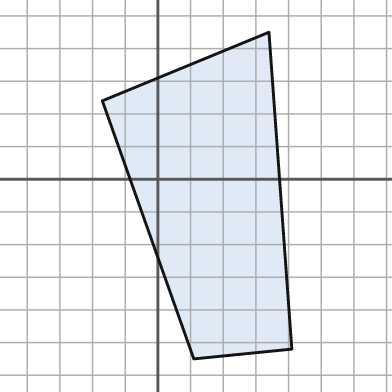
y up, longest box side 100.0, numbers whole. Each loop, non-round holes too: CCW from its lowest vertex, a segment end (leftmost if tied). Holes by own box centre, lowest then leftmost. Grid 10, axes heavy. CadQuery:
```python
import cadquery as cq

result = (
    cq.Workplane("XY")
    .moveTo(11.0, -55.0)
    .lineTo(41.0, -52.0)
    .lineTo(34.0, 45.0)
    .lineTo(-17.0, 24.0)
    .close()
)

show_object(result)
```